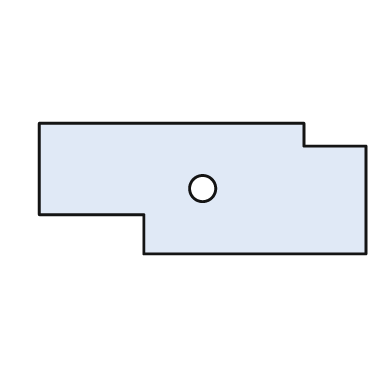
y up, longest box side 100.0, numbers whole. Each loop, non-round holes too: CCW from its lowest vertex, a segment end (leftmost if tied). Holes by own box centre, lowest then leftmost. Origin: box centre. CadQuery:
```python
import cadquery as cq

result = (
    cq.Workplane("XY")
    .moveTo(-18.0, -20.0)
    .lineTo(50.0, -20.0)
    .lineTo(50.0, 13.0)
    .lineTo(31.0, 13.0)
    .lineTo(31.0, 20.0)
    .lineTo(-50.0, 20.0)
    .lineTo(-50.0, -8.0)
    .lineTo(-18.0, -8.0)
    .close()
    .moveTo(0.0, 0.0)
    .circle(4.0)
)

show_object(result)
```